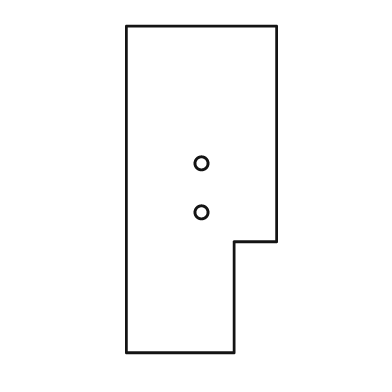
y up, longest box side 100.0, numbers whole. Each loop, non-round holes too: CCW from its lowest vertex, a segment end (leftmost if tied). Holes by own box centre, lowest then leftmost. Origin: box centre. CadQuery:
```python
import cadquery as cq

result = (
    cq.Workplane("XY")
    .moveTo(-23.0, -50.0)
    .lineTo(10.0, -50.0)
    .lineTo(10.0, -16.0)
    .lineTo(23.0, -16.0)
    .lineTo(23.0, 50.0)
    .lineTo(-23.0, 50.0)
    .close()
    .moveTo(0.0, -7.0)
    .circle(2.0)
    .moveTo(0.0, 8.0)
    .circle(2.0)
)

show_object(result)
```